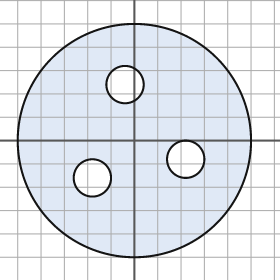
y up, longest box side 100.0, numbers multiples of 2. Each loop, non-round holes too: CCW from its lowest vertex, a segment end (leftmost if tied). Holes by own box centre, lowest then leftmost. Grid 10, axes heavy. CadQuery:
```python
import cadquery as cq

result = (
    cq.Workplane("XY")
    .moveTo(0.0, 0.0)
    .circle(50.0)
    .moveTo(-18.0, -16.0)
    .circle(8.0)
    .moveTo(22.0, -8.0)
    .circle(8.0)
    .moveTo(-4.0, 24.0)
    .circle(8.0)
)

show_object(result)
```